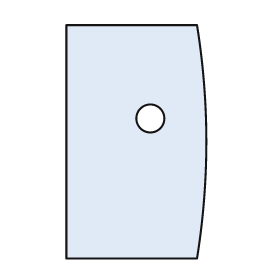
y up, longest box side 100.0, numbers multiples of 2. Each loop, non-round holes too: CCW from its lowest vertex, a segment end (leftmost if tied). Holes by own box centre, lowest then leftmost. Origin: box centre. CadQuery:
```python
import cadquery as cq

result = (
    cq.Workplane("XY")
    .moveTo(-30.0, -50.0)
    .lineTo(26.0, -50.0)
    .threePointArc((30.0, 0.0), (26.0, 50.0))
    .lineTo(-30.0, 50.0)
    .close()
    .moveTo(6.0, 10.0)
    .circle(6.0)
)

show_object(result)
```